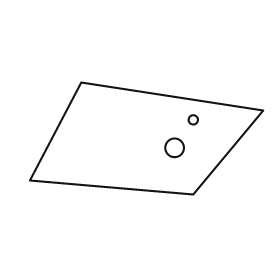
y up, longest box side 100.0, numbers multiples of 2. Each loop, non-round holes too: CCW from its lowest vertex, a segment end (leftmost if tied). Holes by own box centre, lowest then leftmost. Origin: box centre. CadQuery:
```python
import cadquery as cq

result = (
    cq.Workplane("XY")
    .moveTo(20.0, -24.0)
    .lineTo(50.0, 12.0)
    .lineTo(-28.0, 24.0)
    .lineTo(-50.0, -18.0)
    .close()
    .moveTo(12.0, -4.0)
    .circle(4.0)
    .moveTo(20.0, 8.0)
    .circle(2.0)
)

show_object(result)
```